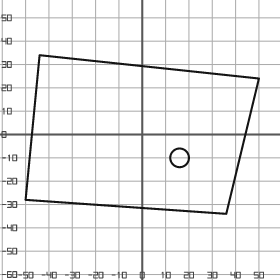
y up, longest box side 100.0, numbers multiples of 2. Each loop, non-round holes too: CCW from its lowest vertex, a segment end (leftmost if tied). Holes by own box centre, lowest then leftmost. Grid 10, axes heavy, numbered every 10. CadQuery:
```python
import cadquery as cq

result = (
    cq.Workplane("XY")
    .moveTo(36.0, -34.0)
    .lineTo(50.0, 24.0)
    .lineTo(-44.0, 34.0)
    .lineTo(-50.0, -28.0)
    .close()
    .moveTo(16.0, -10.0)
    .circle(4.0)
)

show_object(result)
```